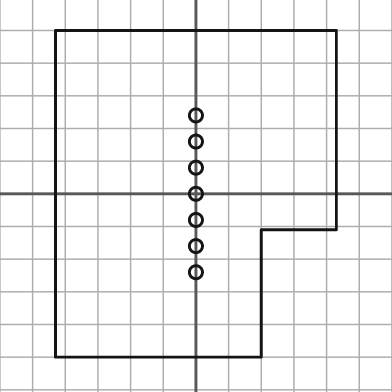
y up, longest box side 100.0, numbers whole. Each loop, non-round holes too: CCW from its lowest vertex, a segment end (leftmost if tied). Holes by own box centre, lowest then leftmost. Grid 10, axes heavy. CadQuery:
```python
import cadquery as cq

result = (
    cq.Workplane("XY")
    .moveTo(-43.0, -50.0)
    .lineTo(20.0, -50.0)
    .lineTo(20.0, -11.0)
    .lineTo(43.0, -11.0)
    .lineTo(43.0, 50.0)
    .lineTo(-43.0, 50.0)
    .close()
    .moveTo(0.0, -24.0)
    .circle(2.0)
    .moveTo(0.0, -16.0)
    .circle(2.0)
    .moveTo(0.0, -8.0)
    .circle(2.0)
    .moveTo(0.0, 0.0)
    .circle(2.0)
    .moveTo(0.0, 8.0)
    .circle(2.0)
    .moveTo(0.0, 16.0)
    .circle(2.0)
    .moveTo(0.0, 24.0)
    .circle(2.0)
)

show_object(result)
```